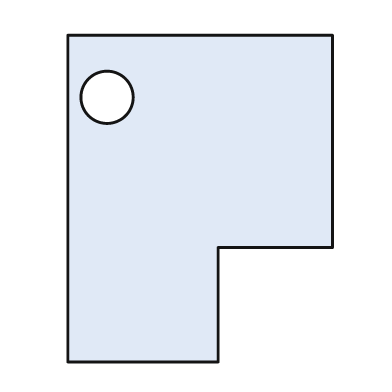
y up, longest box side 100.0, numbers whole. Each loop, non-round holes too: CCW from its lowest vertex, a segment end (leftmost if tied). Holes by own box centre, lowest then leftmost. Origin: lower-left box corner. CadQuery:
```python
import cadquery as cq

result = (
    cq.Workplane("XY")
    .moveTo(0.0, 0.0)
    .lineTo(46.0, 0.0)
    .lineTo(46.0, 35.0)
    .lineTo(81.0, 35.0)
    .lineTo(81.0, 100.0)
    .lineTo(0.0, 100.0)
    .close()
    .moveTo(12.0, 81.0)
    .circle(8.0)
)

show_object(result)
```